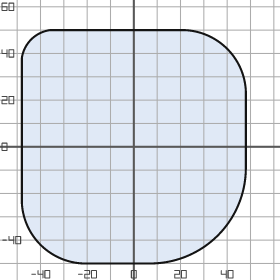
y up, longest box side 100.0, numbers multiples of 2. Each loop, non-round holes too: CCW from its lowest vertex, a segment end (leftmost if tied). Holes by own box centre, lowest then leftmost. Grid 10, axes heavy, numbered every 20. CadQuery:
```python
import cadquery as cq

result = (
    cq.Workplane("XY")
    .moveTo(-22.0, -50.0)
    .lineTo(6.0, -50.0)
    .threePointArc((36.0, -38.0), (48.0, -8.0))
    .lineTo(48.0, 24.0)
    .threePointArc((40.0, 42.0), (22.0, 50.0))
    .lineTo(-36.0, 50.0)
    .threePointArc((-44.0, 46.0), (-48.0, 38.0))
    .lineTo(-48.0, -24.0)
    .threePointArc((-40.0, -42.0), (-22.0, -50.0))
    .close()
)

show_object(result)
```